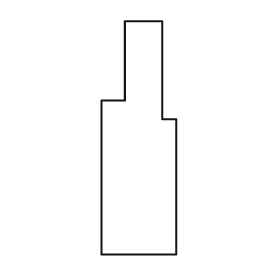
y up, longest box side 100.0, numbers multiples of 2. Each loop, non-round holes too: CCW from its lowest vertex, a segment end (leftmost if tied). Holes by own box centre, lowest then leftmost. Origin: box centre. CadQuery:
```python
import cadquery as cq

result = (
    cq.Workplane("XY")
    .moveTo(-16.0, -50.0)
    .lineTo(16.0, -50.0)
    .lineTo(16.0, 8.0)
    .lineTo(10.0, 8.0)
    .lineTo(10.0, 50.0)
    .lineTo(-6.0, 50.0)
    .lineTo(-6.0, 16.0)
    .lineTo(-16.0, 16.0)
    .close()
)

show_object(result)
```